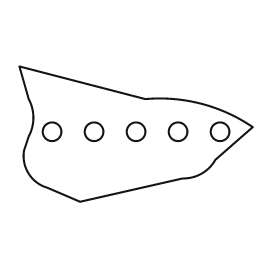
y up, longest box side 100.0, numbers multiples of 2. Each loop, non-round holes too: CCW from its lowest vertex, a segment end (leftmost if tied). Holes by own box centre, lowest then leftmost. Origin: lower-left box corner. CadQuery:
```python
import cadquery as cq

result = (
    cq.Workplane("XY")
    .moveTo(26.0, 0.0)
    .lineTo(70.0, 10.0)
    .threePointArc((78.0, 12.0), (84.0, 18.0))
    .lineTo(100.0, 32.0)
    .threePointArc((78.0, 42.0), (54.0, 44.0))
    .lineTo(0.0, 58.0)
    .lineTo(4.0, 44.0)
    .threePointArc((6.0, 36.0), (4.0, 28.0))
    .lineTo(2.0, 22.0)
    .threePointArc((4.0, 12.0), (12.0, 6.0))
    .close()
    .moveTo(14.0, 30.0)
    .circle(4.0)
    .moveTo(32.0, 30.0)
    .circle(4.0)
    .moveTo(50.0, 30.0)
    .circle(4.0)
    .moveTo(68.0, 30.0)
    .circle(4.0)
    .moveTo(86.0, 30.0)
    .circle(4.0)
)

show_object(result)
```